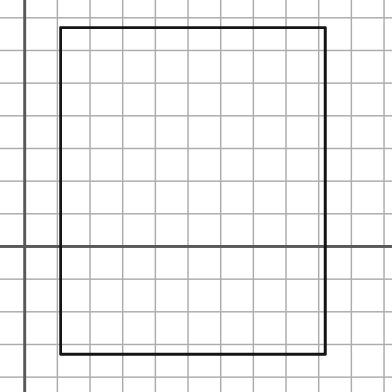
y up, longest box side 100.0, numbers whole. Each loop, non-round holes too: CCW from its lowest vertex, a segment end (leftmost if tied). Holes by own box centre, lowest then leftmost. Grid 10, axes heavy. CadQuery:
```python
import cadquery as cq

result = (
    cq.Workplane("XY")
    .moveTo(11.0, -33.0)
    .lineTo(92.0, -33.0)
    .lineTo(92.0, 67.0)
    .lineTo(11.0, 67.0)
    .close()
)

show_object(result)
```